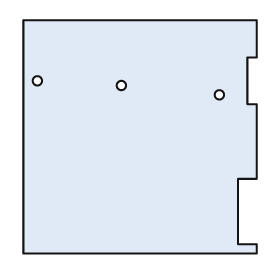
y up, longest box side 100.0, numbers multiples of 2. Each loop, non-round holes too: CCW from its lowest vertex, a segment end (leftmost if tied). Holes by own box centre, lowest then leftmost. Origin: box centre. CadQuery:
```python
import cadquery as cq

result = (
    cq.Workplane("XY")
    .moveTo(-50.0, -50.0)
    .lineTo(50.0, -50.0)
    .lineTo(50.0, -46.0)
    .lineTo(42.0, -46.0)
    .lineTo(42.0, -18.0)
    .lineTo(50.0, -18.0)
    .lineTo(50.0, 14.0)
    .lineTo(46.0, 14.0)
    .lineTo(46.0, 34.0)
    .lineTo(50.0, 34.0)
    .lineTo(50.0, 50.0)
    .lineTo(-50.0, 50.0)
    .close()
    .moveTo(34.0, 18.0)
    .circle(2.0)
    .moveTo(-8.0, 22.0)
    .circle(2.0)
    .moveTo(-44.0, 24.0)
    .circle(2.0)
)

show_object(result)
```